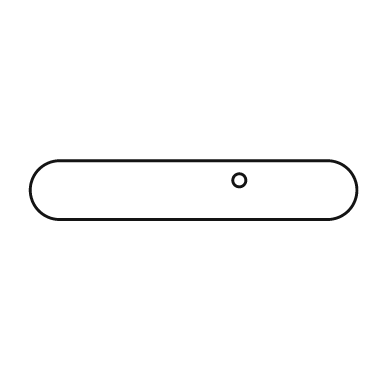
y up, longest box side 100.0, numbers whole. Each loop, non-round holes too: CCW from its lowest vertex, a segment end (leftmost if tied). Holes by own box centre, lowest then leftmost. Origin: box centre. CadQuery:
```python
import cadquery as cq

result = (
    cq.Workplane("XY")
    .moveTo(-41.0, -9.0)
    .lineTo(41.0, -9.0)
    .threePointArc((50.0, 0.0), (41.0, 9.0))
    .lineTo(-41.0, 9.0)
    .threePointArc((-50.0, 0.0), (-41.0, -9.0))
    .close()
    .moveTo(14.0, 3.0)
    .circle(2.0)
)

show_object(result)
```